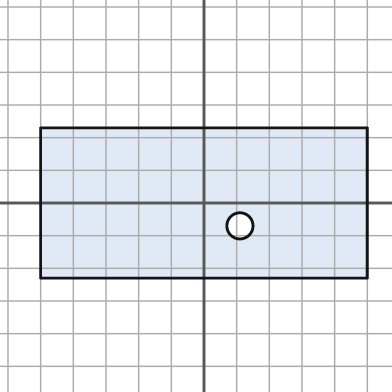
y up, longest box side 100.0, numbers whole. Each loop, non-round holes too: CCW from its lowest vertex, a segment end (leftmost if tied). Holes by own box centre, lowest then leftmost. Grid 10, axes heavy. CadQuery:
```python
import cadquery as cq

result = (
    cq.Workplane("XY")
    .moveTo(-50.0, -23.0)
    .lineTo(50.0, -23.0)
    .lineTo(50.0, 23.0)
    .lineTo(-50.0, 23.0)
    .close()
    .moveTo(11.0, -7.0)
    .circle(4.0)
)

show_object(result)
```